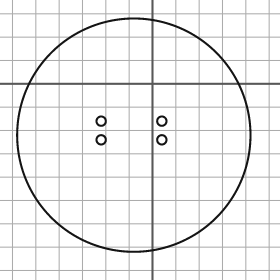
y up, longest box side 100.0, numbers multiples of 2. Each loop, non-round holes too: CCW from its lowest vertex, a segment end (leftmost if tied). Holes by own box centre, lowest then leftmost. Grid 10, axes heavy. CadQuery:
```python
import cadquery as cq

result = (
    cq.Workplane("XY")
    .moveTo(-8.0, -22.0)
    .circle(50.0)
    .moveTo(-22.0, -24.0)
    .circle(2.0)
    .moveTo(4.0, -24.0)
    .circle(2.0)
    .moveTo(-22.0, -16.0)
    .circle(2.0)
    .moveTo(4.0, -16.0)
    .circle(2.0)
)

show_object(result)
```